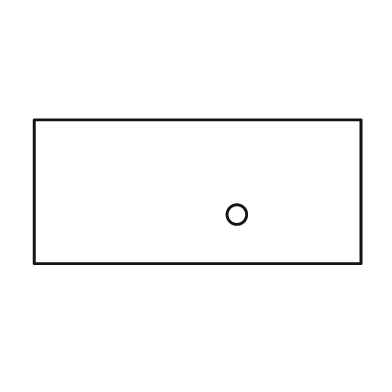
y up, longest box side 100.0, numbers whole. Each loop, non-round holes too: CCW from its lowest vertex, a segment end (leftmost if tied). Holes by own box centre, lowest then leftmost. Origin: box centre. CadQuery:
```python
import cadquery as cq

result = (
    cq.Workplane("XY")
    .moveTo(-50.0, -22.0)
    .lineTo(50.0, -22.0)
    .lineTo(50.0, 22.0)
    .lineTo(-50.0, 22.0)
    .close()
    .moveTo(12.0, -7.0)
    .circle(3.0)
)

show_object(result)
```